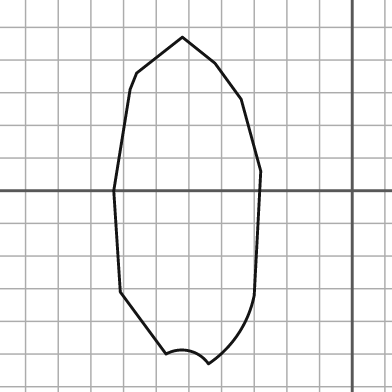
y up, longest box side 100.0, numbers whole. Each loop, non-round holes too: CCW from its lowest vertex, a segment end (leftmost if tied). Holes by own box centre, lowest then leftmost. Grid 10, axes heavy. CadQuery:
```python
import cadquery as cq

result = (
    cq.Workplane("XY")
    .moveTo(-44.0, -53.0)
    .threePointArc((-35.0, -44.0), (-30.0, -32.0))
    .lineTo(-28.0, 6.0)
    .lineTo(-34.0, 28.0)
    .lineTo(-42.0, 39.0)
    .lineTo(-52.0, 47.0)
    .lineTo(-66.0, 36.0)
    .lineTo(-68.0, 31.0)
    .lineTo(-73.0, 0.0)
    .lineTo(-71.0, -31.0)
    .lineTo(-57.0, -50.0)
    .threePointArc((-50.0, -49.0), (-44.0, -53.0))
    .close()
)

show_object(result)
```